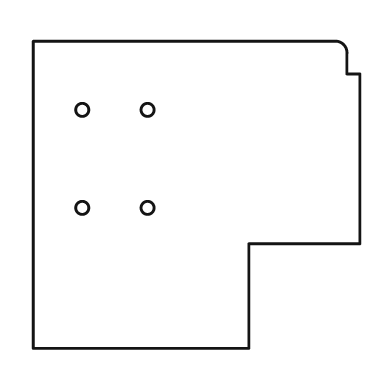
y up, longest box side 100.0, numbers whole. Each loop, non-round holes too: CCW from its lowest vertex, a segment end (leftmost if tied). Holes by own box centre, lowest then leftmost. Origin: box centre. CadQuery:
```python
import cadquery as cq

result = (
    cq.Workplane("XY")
    .moveTo(-50.0, -47.0)
    .lineTo(16.0, -47.0)
    .lineTo(16.0, -15.0)
    .lineTo(50.0, -15.0)
    .lineTo(50.0, 37.0)
    .lineTo(46.0, 37.0)
    .lineTo(46.0, 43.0)
    .threePointArc((45.0, 46.0), (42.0, 47.0))
    .lineTo(-50.0, 47.0)
    .close()
    .moveTo(-35.0, -4.0)
    .circle(2.0)
    .moveTo(-15.0, -4.0)
    .circle(2.0)
    .moveTo(-35.0, 26.0)
    .circle(2.0)
    .moveTo(-15.0, 26.0)
    .circle(2.0)
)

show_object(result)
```